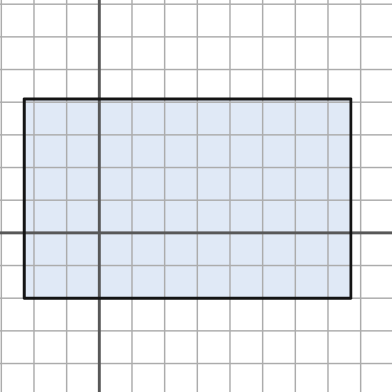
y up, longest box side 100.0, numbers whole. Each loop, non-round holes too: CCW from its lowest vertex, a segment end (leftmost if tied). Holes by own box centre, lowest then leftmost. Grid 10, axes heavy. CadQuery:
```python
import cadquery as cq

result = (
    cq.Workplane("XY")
    .moveTo(-23.0, -20.0)
    .lineTo(77.0, -20.0)
    .lineTo(77.0, 41.0)
    .lineTo(-23.0, 41.0)
    .close()
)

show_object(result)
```